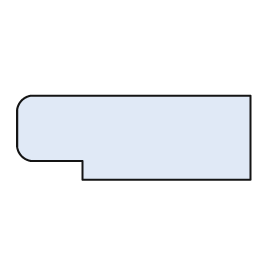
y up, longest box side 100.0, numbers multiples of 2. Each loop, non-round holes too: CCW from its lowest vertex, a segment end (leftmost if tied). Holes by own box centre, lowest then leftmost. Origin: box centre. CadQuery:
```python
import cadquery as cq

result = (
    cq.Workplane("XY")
    .moveTo(-22.0, -18.0)
    .lineTo(50.0, -18.0)
    .lineTo(50.0, 18.0)
    .lineTo(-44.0, 18.0)
    .threePointArc((-48.0, 16.0), (-50.0, 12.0))
    .lineTo(-50.0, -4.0)
    .threePointArc((-48.0, -8.0), (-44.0, -10.0))
    .lineTo(-22.0, -10.0)
    .close()
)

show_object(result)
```